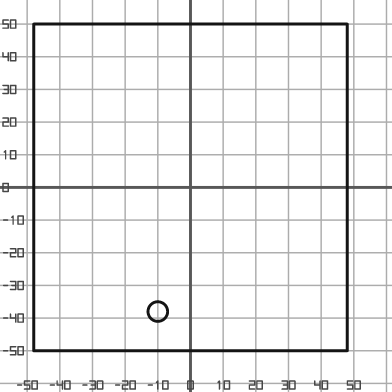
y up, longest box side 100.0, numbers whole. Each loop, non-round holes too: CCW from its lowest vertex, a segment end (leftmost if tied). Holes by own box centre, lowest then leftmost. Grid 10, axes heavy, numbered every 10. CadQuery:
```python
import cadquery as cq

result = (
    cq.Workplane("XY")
    .moveTo(-48.0, -50.0)
    .lineTo(48.0, -50.0)
    .lineTo(48.0, 50.0)
    .lineTo(-48.0, 50.0)
    .close()
    .moveTo(-10.0, -38.0)
    .circle(3.0)
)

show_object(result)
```